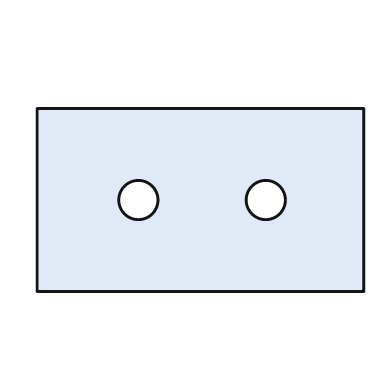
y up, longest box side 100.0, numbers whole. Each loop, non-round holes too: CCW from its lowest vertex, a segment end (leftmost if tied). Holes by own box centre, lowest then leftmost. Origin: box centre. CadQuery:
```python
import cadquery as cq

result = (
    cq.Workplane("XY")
    .moveTo(-50.0, -28.0)
    .lineTo(50.0, -28.0)
    .lineTo(50.0, 28.0)
    .lineTo(-50.0, 28.0)
    .close()
    .moveTo(-19.0, 0.0)
    .circle(6.0)
    .moveTo(20.0, 0.0)
    .circle(6.0)
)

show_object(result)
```